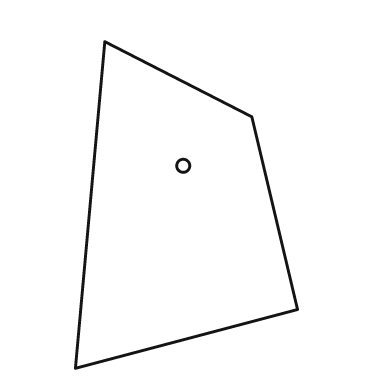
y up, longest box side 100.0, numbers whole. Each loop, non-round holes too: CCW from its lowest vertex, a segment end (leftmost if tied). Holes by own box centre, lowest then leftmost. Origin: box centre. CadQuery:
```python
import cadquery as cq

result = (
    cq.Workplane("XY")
    .moveTo(-34.0, -50.0)
    .lineTo(34.0, -32.0)
    .lineTo(20.0, 27.0)
    .lineTo(-25.0, 50.0)
    .close()
    .moveTo(-1.0, 12.0)
    .circle(2.0)
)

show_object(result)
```